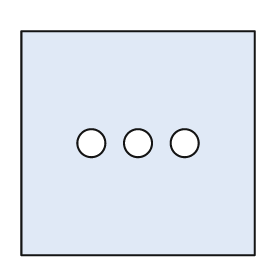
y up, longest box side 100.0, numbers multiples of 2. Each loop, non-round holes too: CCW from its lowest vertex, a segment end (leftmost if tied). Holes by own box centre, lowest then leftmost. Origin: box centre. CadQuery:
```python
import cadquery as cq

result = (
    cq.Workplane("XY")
    .moveTo(-50.0, -48.0)
    .lineTo(50.0, -48.0)
    .lineTo(50.0, 48.0)
    .lineTo(-50.0, 48.0)
    .close()
    .moveTo(-20.0, 0.0)
    .circle(6.0)
    .moveTo(0.0, 0.0)
    .circle(6.0)
    .moveTo(20.0, 0.0)
    .circle(6.0)
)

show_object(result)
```